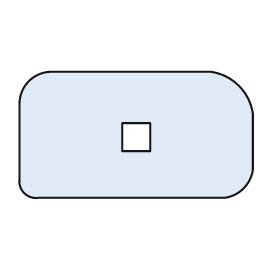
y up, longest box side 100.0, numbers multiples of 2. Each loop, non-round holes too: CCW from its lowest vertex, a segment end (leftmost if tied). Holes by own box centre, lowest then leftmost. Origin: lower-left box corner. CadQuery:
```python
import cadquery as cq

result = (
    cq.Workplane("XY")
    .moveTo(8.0, 0.0)
    .lineTo(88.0, 0.0)
    .threePointArc((96.0, 4.0), (100.0, 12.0))
    .lineTo(100.0, 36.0)
    .threePointArc((94.0, 48.0), (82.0, 54.0))
    .lineTo(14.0, 54.0)
    .threePointArc((4.0, 50.0), (0.0, 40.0))
    .lineTo(0.0, 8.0)
    .threePointArc((2.0, 2.0), (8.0, 0.0))
    .close()
    .moveTo(44.0, 20.0)
    .lineTo(56.0, 20.0)
    .lineTo(56.0, 32.0)
    .lineTo(44.0, 32.0)
    .close()
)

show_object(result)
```